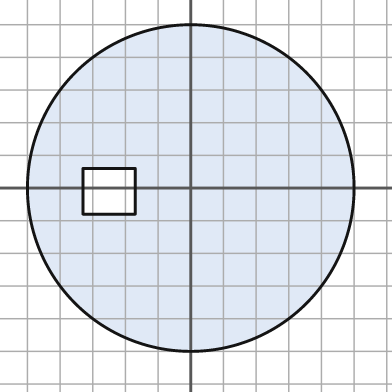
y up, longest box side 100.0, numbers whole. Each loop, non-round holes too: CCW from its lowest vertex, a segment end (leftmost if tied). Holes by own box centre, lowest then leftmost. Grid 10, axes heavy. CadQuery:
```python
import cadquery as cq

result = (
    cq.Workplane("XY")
    .moveTo(0.0, 0.0)
    .circle(50.0)
    .moveTo(-33.0, -8.0)
    .lineTo(-17.0, -8.0)
    .lineTo(-17.0, 6.0)
    .lineTo(-33.0, 6.0)
    .close()
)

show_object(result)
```